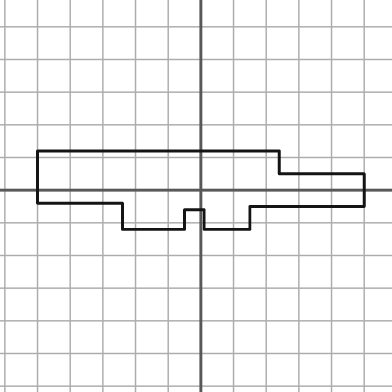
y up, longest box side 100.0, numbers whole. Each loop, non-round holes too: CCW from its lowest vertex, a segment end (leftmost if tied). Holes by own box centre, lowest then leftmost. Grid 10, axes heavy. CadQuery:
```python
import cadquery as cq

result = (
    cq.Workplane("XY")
    .moveTo(-24.0, -12.0)
    .lineTo(-5.0, -12.0)
    .lineTo(-5.0, -6.0)
    .lineTo(1.0, -6.0)
    .lineTo(1.0, -12.0)
    .lineTo(15.0, -12.0)
    .lineTo(15.0, -5.0)
    .lineTo(50.0, -5.0)
    .lineTo(50.0, 5.0)
    .lineTo(24.0, 5.0)
    .lineTo(24.0, 12.0)
    .lineTo(-50.0, 12.0)
    .lineTo(-50.0, -4.0)
    .lineTo(-24.0, -4.0)
    .close()
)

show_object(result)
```